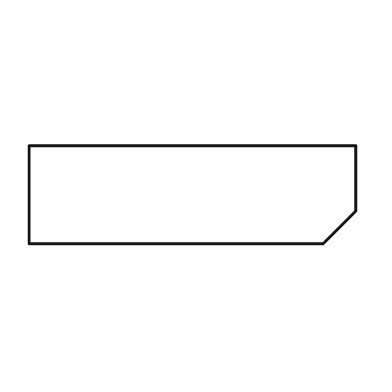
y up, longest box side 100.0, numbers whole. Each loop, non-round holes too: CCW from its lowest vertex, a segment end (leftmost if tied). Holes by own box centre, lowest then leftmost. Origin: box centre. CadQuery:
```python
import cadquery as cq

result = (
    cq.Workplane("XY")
    .moveTo(-50.0, -15.0)
    .lineTo(40.0, -15.0)
    .lineTo(50.0, -5.0)
    .lineTo(50.0, 15.0)
    .lineTo(-50.0, 15.0)
    .close()
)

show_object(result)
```